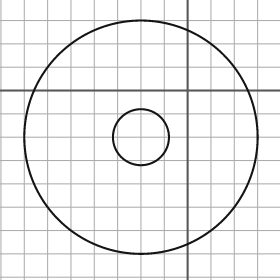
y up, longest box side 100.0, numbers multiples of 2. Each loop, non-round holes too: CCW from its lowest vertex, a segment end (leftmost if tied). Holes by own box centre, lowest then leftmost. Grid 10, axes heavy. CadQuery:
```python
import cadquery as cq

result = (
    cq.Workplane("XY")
    .moveTo(-20.0, -20.0)
    .circle(50.0)
    .moveTo(-20.0, -20.0)
    .circle(12.0)
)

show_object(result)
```